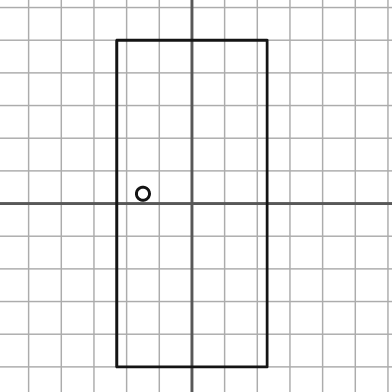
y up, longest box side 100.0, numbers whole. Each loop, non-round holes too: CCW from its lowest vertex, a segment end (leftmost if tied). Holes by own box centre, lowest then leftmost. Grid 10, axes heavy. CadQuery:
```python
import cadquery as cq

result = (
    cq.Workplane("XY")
    .moveTo(-23.0, -50.0)
    .lineTo(23.0, -50.0)
    .lineTo(23.0, 50.0)
    .lineTo(-23.0, 50.0)
    .close()
    .moveTo(-15.0, 3.0)
    .circle(2.0)
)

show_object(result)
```